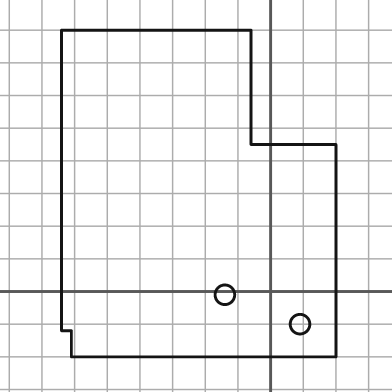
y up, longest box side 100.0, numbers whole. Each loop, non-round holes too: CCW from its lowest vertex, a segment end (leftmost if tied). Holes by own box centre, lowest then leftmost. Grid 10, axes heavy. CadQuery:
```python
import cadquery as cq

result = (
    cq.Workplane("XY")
    .moveTo(-61.0, -20.0)
    .lineTo(20.0, -20.0)
    .lineTo(20.0, 45.0)
    .lineTo(-6.0, 45.0)
    .lineTo(-6.0, 80.0)
    .lineTo(-64.0, 80.0)
    .lineTo(-64.0, -12.0)
    .lineTo(-61.0, -12.0)
    .close()
    .moveTo(9.0, -10.0)
    .circle(3.0)
    .moveTo(-14.0, -1.0)
    .circle(3.0)
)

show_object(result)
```